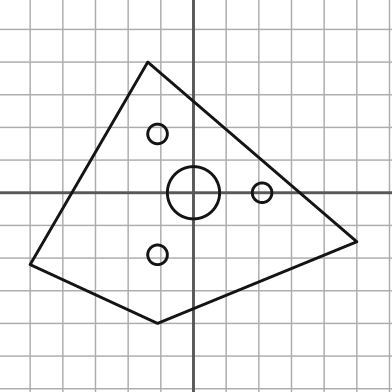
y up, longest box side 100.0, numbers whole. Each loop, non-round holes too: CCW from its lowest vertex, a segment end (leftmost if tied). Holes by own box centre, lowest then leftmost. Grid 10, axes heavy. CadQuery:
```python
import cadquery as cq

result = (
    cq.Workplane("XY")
    .moveTo(-11.0, -40.0)
    .lineTo(50.0, -15.0)
    .lineTo(-14.0, 40.0)
    .lineTo(-50.0, -22.0)
    .close()
    .moveTo(-11.0, -19.0)
    .circle(3.0)
    .moveTo(0.0, 0.0)
    .circle(8.0)
    .moveTo(21.0, 0.0)
    .circle(3.0)
    .moveTo(-11.0, 18.0)
    .circle(3.0)
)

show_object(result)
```